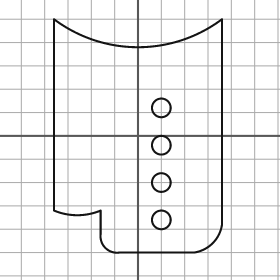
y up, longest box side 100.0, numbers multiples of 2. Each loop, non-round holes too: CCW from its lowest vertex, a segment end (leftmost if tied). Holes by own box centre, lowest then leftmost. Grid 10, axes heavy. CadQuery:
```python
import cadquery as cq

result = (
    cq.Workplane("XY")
    .moveTo(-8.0, -50.0)
    .lineTo(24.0, -50.0)
    .threePointArc((32.0, -46.0), (36.0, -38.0))
    .lineTo(36.0, 50.0)
    .threePointArc((0.0, 38.0), (-36.0, 50.0))
    .lineTo(-36.0, -32.0)
    .threePointArc((-26.0, -34.0), (-16.0, -32.0))
    .lineTo(-16.0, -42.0)
    .threePointArc((-14.0, -48.0), (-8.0, -50.0))
    .close()
    .moveTo(10.0, -36.0)
    .circle(4.0)
    .moveTo(10.0, -20.0)
    .circle(4.0)
    .moveTo(10.0, -4.0)
    .circle(4.0)
    .moveTo(10.0, 12.0)
    .circle(4.0)
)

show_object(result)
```